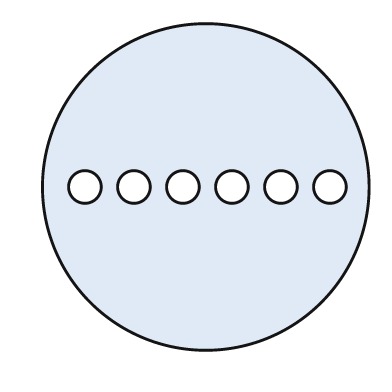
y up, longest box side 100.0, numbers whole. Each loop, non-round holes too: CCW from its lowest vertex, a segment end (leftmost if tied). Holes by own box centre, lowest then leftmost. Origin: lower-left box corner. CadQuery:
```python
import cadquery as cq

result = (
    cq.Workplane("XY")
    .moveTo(50.0, 50.0)
    .circle(50.0)
    .moveTo(13.0, 50.0)
    .circle(5.0)
    .moveTo(28.0, 50.0)
    .circle(5.0)
    .moveTo(43.0, 50.0)
    .circle(5.0)
    .moveTo(58.0, 50.0)
    .circle(5.0)
    .moveTo(73.0, 50.0)
    .circle(5.0)
    .moveTo(88.0, 50.0)
    .circle(5.0)
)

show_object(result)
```